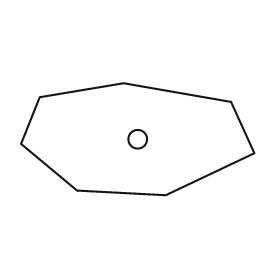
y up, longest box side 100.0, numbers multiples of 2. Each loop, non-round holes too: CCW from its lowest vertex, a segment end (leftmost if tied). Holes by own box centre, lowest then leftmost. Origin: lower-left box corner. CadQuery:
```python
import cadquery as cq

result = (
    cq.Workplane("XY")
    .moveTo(62.0, 0.0)
    .lineTo(100.0, 18.0)
    .lineTo(90.0, 40.0)
    .lineTo(44.0, 48.0)
    .lineTo(8.0, 42.0)
    .lineTo(0.0, 22.0)
    .lineTo(24.0, 2.0)
    .close()
    .moveTo(50.0, 24.0)
    .circle(4.0)
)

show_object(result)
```